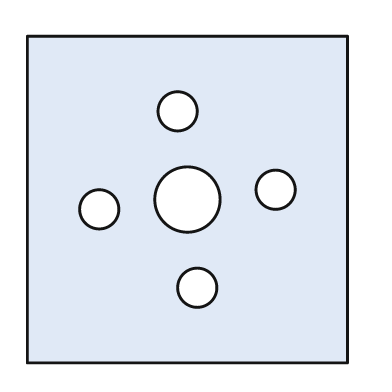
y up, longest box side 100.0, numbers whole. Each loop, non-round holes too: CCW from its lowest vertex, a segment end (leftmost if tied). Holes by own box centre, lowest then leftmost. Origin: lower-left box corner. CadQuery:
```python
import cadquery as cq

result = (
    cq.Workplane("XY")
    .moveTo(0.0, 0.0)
    .lineTo(98.0, 0.0)
    .lineTo(98.0, 100.0)
    .lineTo(0.0, 100.0)
    .close()
    .moveTo(52.0, 23.0)
    .circle(6.0)
    .moveTo(22.0, 47.0)
    .circle(6.0)
    .moveTo(49.0, 50.0)
    .circle(10.0)
    .moveTo(76.0, 53.0)
    .circle(6.0)
    .moveTo(46.0, 77.0)
    .circle(6.0)
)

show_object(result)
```